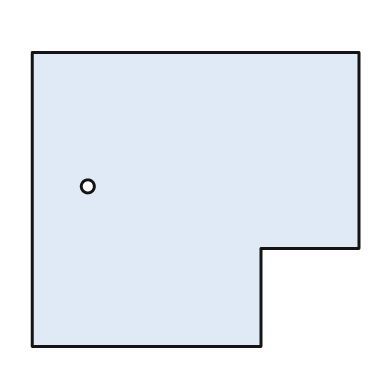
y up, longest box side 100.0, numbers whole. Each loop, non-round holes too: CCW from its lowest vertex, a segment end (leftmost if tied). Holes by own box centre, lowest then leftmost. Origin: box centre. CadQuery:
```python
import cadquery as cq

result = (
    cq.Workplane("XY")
    .moveTo(-50.0, -45.0)
    .lineTo(20.0, -45.0)
    .lineTo(20.0, -15.0)
    .lineTo(50.0, -15.0)
    .lineTo(50.0, 45.0)
    .lineTo(-50.0, 45.0)
    .close()
    .moveTo(-33.0, 4.0)
    .circle(2.0)
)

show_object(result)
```